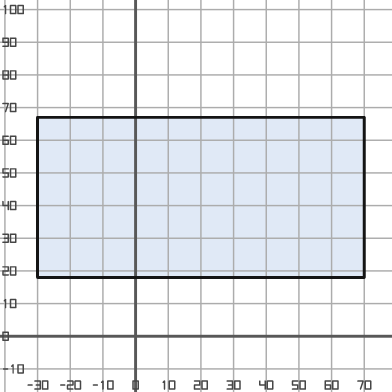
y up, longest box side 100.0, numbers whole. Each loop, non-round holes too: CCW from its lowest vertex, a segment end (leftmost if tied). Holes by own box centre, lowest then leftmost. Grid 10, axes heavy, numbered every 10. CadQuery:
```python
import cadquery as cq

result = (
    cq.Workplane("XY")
    .moveTo(-30.0, 18.0)
    .lineTo(70.0, 18.0)
    .lineTo(70.0, 67.0)
    .lineTo(-30.0, 67.0)
    .close()
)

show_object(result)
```